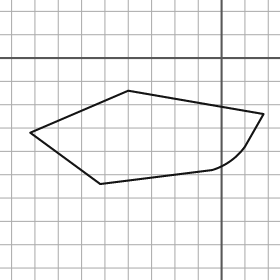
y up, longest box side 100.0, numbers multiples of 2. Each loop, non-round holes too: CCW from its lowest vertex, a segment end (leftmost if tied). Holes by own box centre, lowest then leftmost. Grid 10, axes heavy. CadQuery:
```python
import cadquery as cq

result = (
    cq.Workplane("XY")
    .moveTo(-52.0, -54.0)
    .lineTo(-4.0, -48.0)
    .threePointArc((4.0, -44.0), (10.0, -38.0))
    .lineTo(18.0, -24.0)
    .lineTo(-40.0, -14.0)
    .lineTo(-82.0, -32.0)
    .close()
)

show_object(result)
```